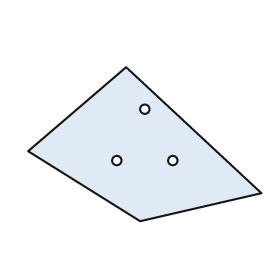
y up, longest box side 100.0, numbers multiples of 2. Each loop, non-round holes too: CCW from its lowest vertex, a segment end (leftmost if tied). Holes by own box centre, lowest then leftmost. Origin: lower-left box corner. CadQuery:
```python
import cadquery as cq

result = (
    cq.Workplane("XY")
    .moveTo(48.0, 0.0)
    .lineTo(100.0, 12.0)
    .lineTo(42.0, 66.0)
    .lineTo(0.0, 30.0)
    .close()
    .moveTo(38.0, 26.0)
    .circle(2.0)
    .moveTo(62.0, 26.0)
    .circle(2.0)
    .moveTo(50.0, 48.0)
    .circle(2.0)
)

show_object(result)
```